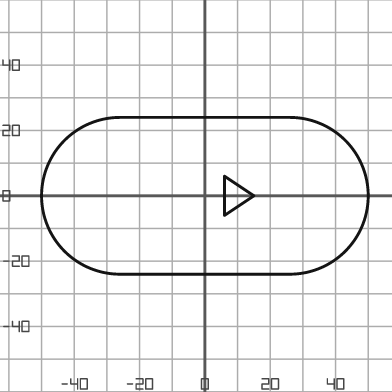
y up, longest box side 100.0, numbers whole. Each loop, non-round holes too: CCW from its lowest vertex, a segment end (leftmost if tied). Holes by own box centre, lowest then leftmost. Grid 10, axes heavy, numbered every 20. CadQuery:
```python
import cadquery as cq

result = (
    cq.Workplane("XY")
    .moveTo(-26.0, -24.0)
    .lineTo(26.0, -24.0)
    .threePointArc((50.0, 0.0), (26.0, 24.0))
    .lineTo(-26.0, 24.0)
    .threePointArc((-50.0, 0.0), (-26.0, -24.0))
    .close()
    .moveTo(6.0, -6.0)
    .lineTo(15.0, 0.0)
    .lineTo(6.0, 6.0)
    .close()
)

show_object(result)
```